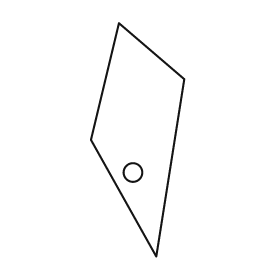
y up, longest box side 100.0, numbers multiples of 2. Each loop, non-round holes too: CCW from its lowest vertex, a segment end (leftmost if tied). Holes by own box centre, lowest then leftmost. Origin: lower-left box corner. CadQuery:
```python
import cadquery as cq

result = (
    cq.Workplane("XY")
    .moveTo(28.0, 0.0)
    .lineTo(40.0, 76.0)
    .lineTo(12.0, 100.0)
    .lineTo(0.0, 50.0)
    .close()
    .moveTo(18.0, 36.0)
    .circle(4.0)
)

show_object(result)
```